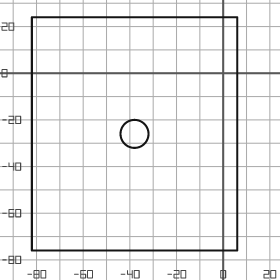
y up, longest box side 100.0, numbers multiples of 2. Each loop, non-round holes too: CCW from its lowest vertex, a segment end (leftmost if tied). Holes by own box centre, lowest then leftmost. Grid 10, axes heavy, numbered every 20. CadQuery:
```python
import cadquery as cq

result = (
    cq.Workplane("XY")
    .moveTo(-82.0, -76.0)
    .lineTo(6.0, -76.0)
    .lineTo(6.0, 24.0)
    .lineTo(-82.0, 24.0)
    .close()
    .moveTo(-38.0, -26.0)
    .circle(6.0)
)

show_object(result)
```